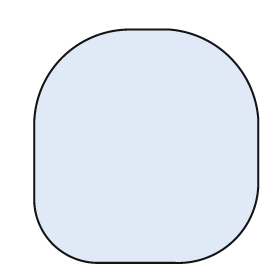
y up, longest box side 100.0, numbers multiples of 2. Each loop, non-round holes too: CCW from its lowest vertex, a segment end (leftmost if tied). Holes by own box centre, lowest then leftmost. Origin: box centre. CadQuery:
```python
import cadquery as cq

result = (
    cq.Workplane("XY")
    .moveTo(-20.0, -50.0)
    .lineTo(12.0, -50.0)
    .threePointArc((38.0, -40.0), (48.0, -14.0))
    .lineTo(48.0, 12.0)
    .threePointArc((36.0, 38.0), (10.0, 50.0))
    .lineTo(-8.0, 50.0)
    .threePointArc((-36.0, 38.0), (-48.0, 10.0))
    .lineTo(-48.0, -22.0)
    .threePointArc((-40.0, -42.0), (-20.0, -50.0))
    .close()
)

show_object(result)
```